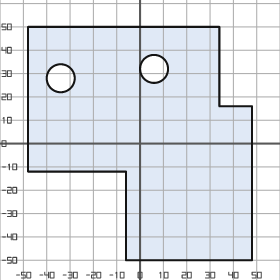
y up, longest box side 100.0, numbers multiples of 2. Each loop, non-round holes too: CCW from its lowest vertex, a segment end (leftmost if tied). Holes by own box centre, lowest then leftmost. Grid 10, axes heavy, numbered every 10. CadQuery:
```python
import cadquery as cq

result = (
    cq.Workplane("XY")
    .moveTo(-6.0, -50.0)
    .lineTo(48.0, -50.0)
    .lineTo(48.0, 16.0)
    .lineTo(34.0, 16.0)
    .lineTo(34.0, 50.0)
    .lineTo(-48.0, 50.0)
    .lineTo(-48.0, -12.0)
    .lineTo(-6.0, -12.0)
    .close()
    .moveTo(-34.0, 28.0)
    .circle(6.0)
    .moveTo(6.0, 32.0)
    .circle(6.0)
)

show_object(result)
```